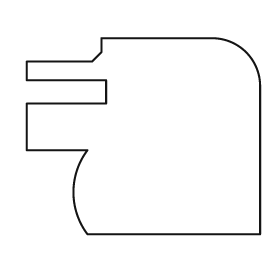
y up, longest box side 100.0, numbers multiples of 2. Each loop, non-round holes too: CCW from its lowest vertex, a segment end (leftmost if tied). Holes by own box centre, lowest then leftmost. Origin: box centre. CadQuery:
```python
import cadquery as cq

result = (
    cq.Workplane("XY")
    .moveTo(-24.0, -42.0)
    .lineTo(50.0, -42.0)
    .lineTo(50.0, 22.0)
    .threePointArc((44.0, 36.0), (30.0, 42.0))
    .lineTo(-18.0, 42.0)
    .lineTo(-18.0, 36.0)
    .lineTo(-22.0, 32.0)
    .lineTo(-50.0, 32.0)
    .lineTo(-50.0, 24.0)
    .lineTo(-16.0, 24.0)
    .lineTo(-16.0, 14.0)
    .lineTo(-50.0, 14.0)
    .lineTo(-50.0, -6.0)
    .lineTo(-24.0, -6.0)
    .threePointArc((-30.0, -24.0), (-24.0, -42.0))
    .close()
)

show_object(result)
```